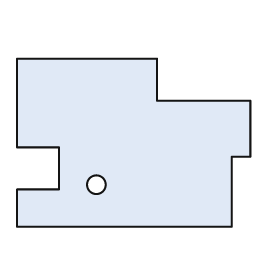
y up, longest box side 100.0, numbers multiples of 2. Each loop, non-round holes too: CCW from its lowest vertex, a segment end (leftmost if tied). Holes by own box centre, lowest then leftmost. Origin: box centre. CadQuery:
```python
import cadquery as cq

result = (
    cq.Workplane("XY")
    .moveTo(-50.0, -36.0)
    .lineTo(42.0, -36.0)
    .lineTo(42.0, -6.0)
    .lineTo(50.0, -6.0)
    .lineTo(50.0, 18.0)
    .lineTo(10.0, 18.0)
    .lineTo(10.0, 36.0)
    .lineTo(-50.0, 36.0)
    .lineTo(-50.0, -2.0)
    .lineTo(-32.0, -2.0)
    .lineTo(-32.0, -20.0)
    .lineTo(-50.0, -20.0)
    .close()
    .moveTo(-16.0, -18.0)
    .circle(4.0)
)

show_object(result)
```